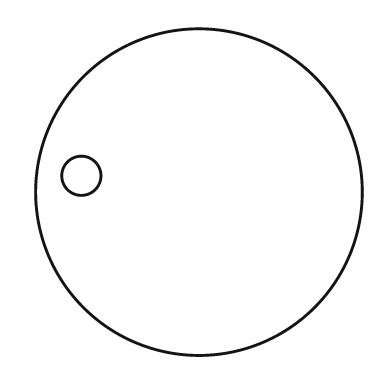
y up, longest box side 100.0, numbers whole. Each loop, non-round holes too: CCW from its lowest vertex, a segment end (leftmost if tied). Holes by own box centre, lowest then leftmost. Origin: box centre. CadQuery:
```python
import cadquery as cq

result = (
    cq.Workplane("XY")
    .moveTo(0.0, 0.0)
    .circle(50.0)
    .moveTo(-36.0, 5.0)
    .circle(6.0)
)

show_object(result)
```